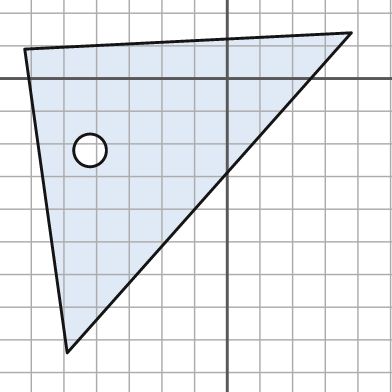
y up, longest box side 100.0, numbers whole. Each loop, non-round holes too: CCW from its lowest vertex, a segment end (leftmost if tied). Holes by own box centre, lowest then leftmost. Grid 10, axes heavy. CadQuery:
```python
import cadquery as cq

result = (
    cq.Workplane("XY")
    .moveTo(-49.0, -84.0)
    .lineTo(38.0, 14.0)
    .lineTo(-62.0, 9.0)
    .close()
    .moveTo(-42.0, -22.0)
    .circle(5.0)
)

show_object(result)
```